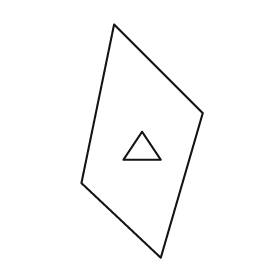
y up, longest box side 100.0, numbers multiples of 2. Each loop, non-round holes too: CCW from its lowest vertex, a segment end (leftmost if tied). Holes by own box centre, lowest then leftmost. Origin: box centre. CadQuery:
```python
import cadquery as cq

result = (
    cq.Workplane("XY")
    .moveTo(8.0, -50.0)
    .lineTo(26.0, 12.0)
    .lineTo(-12.0, 50.0)
    .lineTo(-26.0, -18.0)
    .close()
    .moveTo(-8.0, -8.0)
    .lineTo(8.0, -8.0)
    .lineTo(0.0, 4.0)
    .close()
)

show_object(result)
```